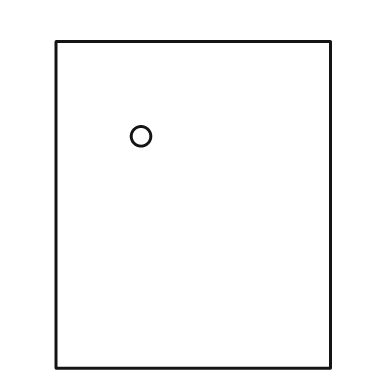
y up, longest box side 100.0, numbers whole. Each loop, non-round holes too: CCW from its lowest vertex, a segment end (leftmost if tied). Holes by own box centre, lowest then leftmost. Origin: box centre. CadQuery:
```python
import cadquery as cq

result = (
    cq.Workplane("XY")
    .moveTo(-42.0, -50.0)
    .lineTo(42.0, -50.0)
    .lineTo(42.0, 50.0)
    .lineTo(-42.0, 50.0)
    .close()
    .moveTo(-16.0, 21.0)
    .circle(3.0)
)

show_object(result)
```